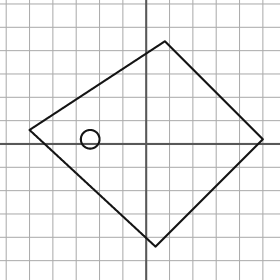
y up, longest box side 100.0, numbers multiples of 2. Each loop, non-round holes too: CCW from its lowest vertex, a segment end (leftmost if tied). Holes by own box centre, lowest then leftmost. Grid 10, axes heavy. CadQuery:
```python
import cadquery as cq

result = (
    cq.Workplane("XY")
    .moveTo(4.0, -44.0)
    .lineTo(50.0, 2.0)
    .lineTo(8.0, 44.0)
    .lineTo(-50.0, 6.0)
    .close()
    .moveTo(-24.0, 2.0)
    .circle(4.0)
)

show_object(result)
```